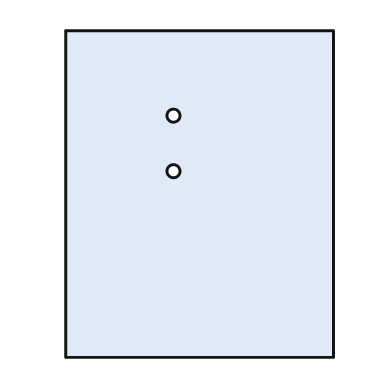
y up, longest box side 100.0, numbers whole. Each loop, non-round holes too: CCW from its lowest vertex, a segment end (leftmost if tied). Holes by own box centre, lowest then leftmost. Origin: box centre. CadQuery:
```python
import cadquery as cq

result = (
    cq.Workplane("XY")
    .moveTo(-41.0, -50.0)
    .lineTo(41.0, -50.0)
    .lineTo(41.0, 50.0)
    .lineTo(-41.0, 50.0)
    .close()
    .moveTo(-8.0, 7.0)
    .circle(2.0)
    .moveTo(-8.0, 24.0)
    .circle(2.0)
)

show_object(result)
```